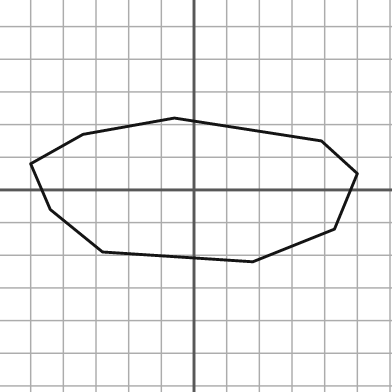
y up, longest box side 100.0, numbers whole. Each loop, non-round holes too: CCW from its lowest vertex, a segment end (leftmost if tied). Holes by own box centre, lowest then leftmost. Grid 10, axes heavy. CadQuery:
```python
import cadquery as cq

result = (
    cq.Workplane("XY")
    .moveTo(18.0, -22.0)
    .lineTo(43.0, -12.0)
    .lineTo(50.0, 5.0)
    .lineTo(39.0, 15.0)
    .lineTo(-6.0, 22.0)
    .lineTo(-34.0, 17.0)
    .lineTo(-50.0, 8.0)
    .lineTo(-44.0, -6.0)
    .lineTo(-28.0, -19.0)
    .close()
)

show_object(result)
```